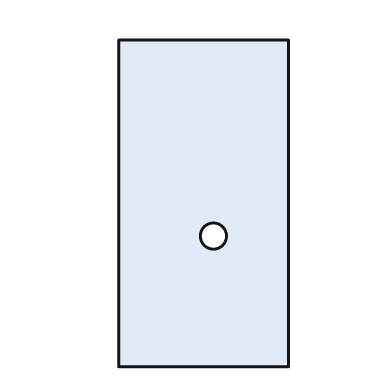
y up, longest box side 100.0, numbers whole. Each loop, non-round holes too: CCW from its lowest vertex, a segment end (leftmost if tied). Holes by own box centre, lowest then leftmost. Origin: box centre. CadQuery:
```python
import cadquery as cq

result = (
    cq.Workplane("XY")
    .moveTo(-26.0, -50.0)
    .lineTo(26.0, -50.0)
    .lineTo(26.0, 50.0)
    .lineTo(-26.0, 50.0)
    .close()
    .moveTo(3.0, -10.0)
    .circle(4.0)
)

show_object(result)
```